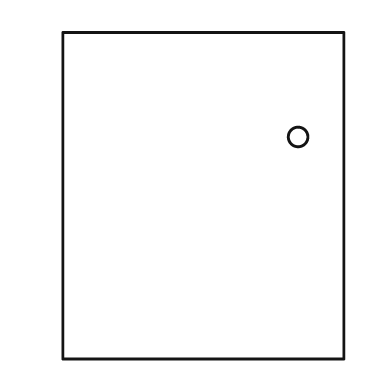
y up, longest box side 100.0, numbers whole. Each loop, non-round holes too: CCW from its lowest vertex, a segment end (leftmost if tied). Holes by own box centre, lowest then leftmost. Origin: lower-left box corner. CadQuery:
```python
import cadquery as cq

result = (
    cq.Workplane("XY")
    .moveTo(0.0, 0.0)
    .lineTo(86.0, 0.0)
    .lineTo(86.0, 100.0)
    .lineTo(0.0, 100.0)
    .close()
    .moveTo(72.0, 68.0)
    .circle(3.0)
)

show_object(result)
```